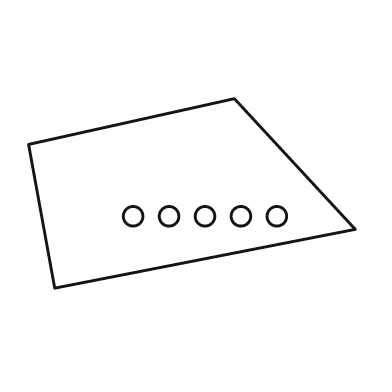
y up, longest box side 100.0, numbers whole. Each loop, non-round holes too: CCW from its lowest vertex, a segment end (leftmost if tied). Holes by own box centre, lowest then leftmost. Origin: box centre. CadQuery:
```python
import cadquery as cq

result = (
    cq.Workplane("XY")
    .moveTo(-42.0, -29.0)
    .lineTo(50.0, -11.0)
    .lineTo(13.0, 29.0)
    .lineTo(-50.0, 15.0)
    .close()
    .moveTo(-18.0, -7.0)
    .circle(3.0)
    .moveTo(-7.0, -7.0)
    .circle(3.0)
    .moveTo(4.0, -7.0)
    .circle(3.0)
    .moveTo(15.0, -7.0)
    .circle(3.0)
    .moveTo(26.0, -7.0)
    .circle(3.0)
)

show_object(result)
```